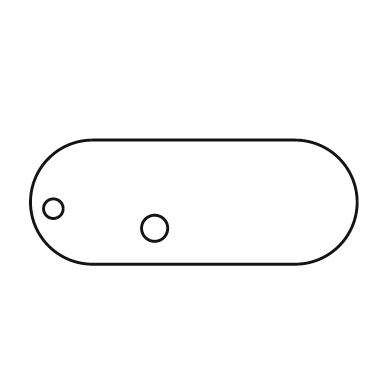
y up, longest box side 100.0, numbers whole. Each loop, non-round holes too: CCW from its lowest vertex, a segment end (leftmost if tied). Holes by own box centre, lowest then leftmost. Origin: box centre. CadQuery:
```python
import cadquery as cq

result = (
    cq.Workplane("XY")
    .moveTo(-31.0, -19.0)
    .lineTo(31.0, -19.0)
    .threePointArc((50.0, 0.0), (31.0, 19.0))
    .lineTo(-31.0, 19.0)
    .threePointArc((-50.0, 0.0), (-31.0, -19.0))
    .close()
    .moveTo(-12.0, -8.0)
    .circle(4.0)
    .moveTo(-43.0, -2.0)
    .circle(3.0)
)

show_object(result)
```